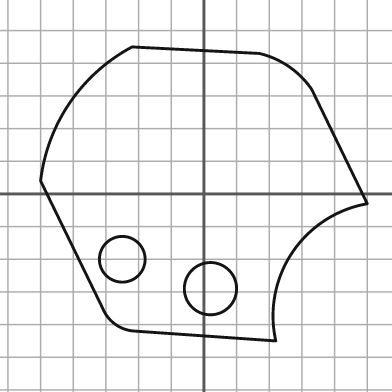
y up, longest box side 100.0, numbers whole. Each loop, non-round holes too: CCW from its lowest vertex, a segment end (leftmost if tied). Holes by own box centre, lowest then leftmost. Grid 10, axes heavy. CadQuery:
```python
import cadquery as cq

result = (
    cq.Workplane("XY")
    .moveTo(22.0, -45.0)
    .threePointArc((27.0, -18.0), (50.0, -3.0))
    .lineTo(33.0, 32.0)
    .threePointArc((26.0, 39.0), (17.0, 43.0))
    .lineTo(-22.0, 45.0)
    .threePointArc((-41.0, 28.0), (-50.0, 4.0))
    .lineTo(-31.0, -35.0)
    .threePointArc((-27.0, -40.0), (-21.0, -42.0))
    .close()
    .moveTo(2.0, -29.0)
    .circle(8.0)
    .moveTo(-25.0, -20.0)
    .circle(7.0)
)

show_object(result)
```